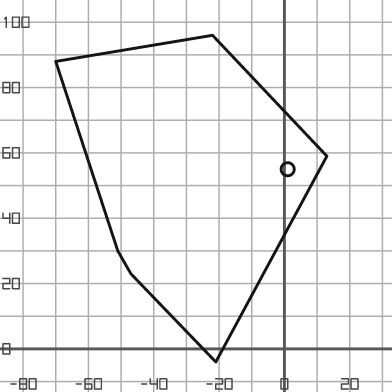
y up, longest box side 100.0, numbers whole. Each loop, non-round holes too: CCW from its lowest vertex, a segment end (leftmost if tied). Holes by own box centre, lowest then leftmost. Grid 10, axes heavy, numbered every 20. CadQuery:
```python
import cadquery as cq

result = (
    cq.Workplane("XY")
    .moveTo(-21.0, -4.0)
    .lineTo(13.0, 59.0)
    .lineTo(-22.0, 96.0)
    .lineTo(-70.0, 88.0)
    .lineTo(-51.0, 30.0)
    .lineTo(-47.0, 23.0)
    .close()
    .moveTo(1.0, 55.0)
    .circle(2.0)
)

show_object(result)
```